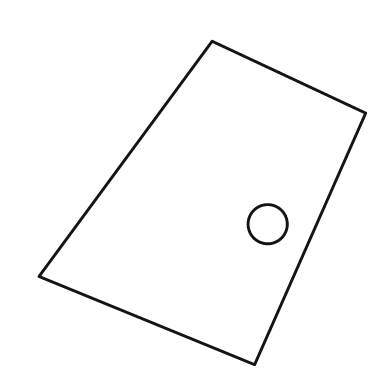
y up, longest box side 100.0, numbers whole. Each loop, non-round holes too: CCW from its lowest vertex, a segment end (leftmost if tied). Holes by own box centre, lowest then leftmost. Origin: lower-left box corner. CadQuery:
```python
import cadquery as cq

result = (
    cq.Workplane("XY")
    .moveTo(66.0, 0.0)
    .lineTo(100.0, 77.0)
    .lineTo(53.0, 99.0)
    .lineTo(0.0, 27.0)
    .close()
    .moveTo(70.0, 43.0)
    .circle(6.0)
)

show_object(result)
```